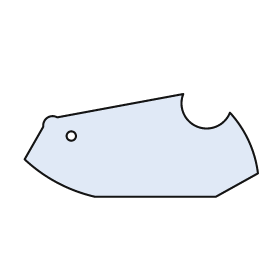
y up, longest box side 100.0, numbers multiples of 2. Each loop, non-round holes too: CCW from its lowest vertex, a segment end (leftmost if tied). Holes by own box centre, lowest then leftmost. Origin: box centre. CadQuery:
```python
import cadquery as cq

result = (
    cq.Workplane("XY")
    .moveTo(-20.0, -22.0)
    .lineTo(32.0, -22.0)
    .lineTo(50.0, -12.0)
    .threePointArc((46.0, 2.0), (38.0, 14.0))
    .threePointArc((24.0, 8.0), (18.0, 22.0))
    .lineTo(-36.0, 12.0)
    .threePointArc((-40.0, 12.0), (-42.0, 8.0))
    .lineTo(-50.0, -6.0)
    .threePointArc((-36.0, -16.0), (-20.0, -22.0))
    .close()
    .moveTo(-30.0, 4.0)
    .circle(2.0)
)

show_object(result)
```